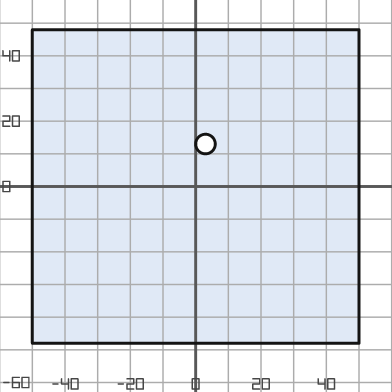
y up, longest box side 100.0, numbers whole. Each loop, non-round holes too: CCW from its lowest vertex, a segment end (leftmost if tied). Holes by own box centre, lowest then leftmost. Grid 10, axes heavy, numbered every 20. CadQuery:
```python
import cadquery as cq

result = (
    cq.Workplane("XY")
    .moveTo(-50.0, -48.0)
    .lineTo(50.0, -48.0)
    .lineTo(50.0, 48.0)
    .lineTo(-50.0, 48.0)
    .close()
    .moveTo(3.0, 13.0)
    .circle(3.0)
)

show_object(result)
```